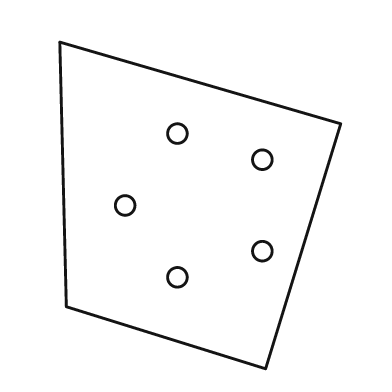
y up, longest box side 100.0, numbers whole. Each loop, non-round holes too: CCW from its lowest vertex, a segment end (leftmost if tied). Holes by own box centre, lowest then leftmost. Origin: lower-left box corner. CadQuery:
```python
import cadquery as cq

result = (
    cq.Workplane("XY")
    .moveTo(63.0, 0.0)
    .lineTo(86.0, 75.0)
    .lineTo(0.0, 100.0)
    .lineTo(2.0, 19.0)
    .close()
    .moveTo(36.0, 28.0)
    .circle(3.0)
    .moveTo(62.0, 36.0)
    .circle(3.0)
    .moveTo(20.0, 50.0)
    .circle(3.0)
    .moveTo(62.0, 64.0)
    .circle(3.0)
    .moveTo(36.0, 72.0)
    .circle(3.0)
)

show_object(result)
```